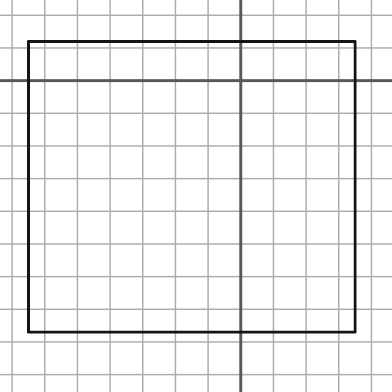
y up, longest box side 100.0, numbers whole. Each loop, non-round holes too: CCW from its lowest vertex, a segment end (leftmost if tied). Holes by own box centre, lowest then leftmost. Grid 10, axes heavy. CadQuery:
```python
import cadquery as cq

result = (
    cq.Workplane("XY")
    .moveTo(-65.0, -77.0)
    .lineTo(35.0, -77.0)
    .lineTo(35.0, 12.0)
    .lineTo(-65.0, 12.0)
    .close()
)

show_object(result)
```